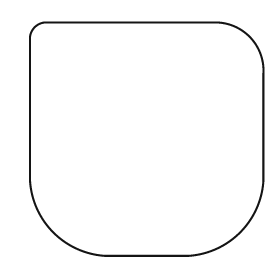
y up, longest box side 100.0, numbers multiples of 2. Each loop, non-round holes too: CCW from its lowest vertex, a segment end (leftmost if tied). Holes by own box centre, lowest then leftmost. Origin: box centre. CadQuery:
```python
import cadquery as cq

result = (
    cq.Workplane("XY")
    .moveTo(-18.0, -50.0)
    .lineTo(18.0, -50.0)
    .threePointArc((40.0, -40.0), (50.0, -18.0))
    .lineTo(50.0, 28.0)
    .threePointArc((44.0, 44.0), (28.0, 50.0))
    .lineTo(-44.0, 50.0)
    .threePointArc((-48.0, 48.0), (-50.0, 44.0))
    .lineTo(-50.0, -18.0)
    .threePointArc((-40.0, -40.0), (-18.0, -50.0))
    .close()
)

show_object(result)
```